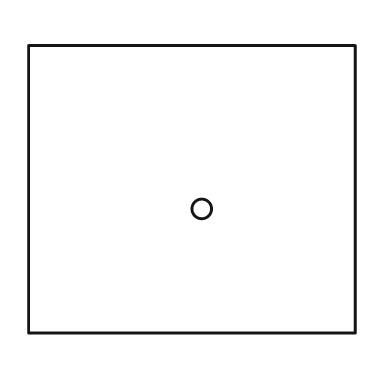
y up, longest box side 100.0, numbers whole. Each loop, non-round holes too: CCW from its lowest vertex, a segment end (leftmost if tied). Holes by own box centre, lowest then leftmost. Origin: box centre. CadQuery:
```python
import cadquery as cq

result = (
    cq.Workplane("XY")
    .moveTo(-50.0, -44.0)
    .lineTo(50.0, -44.0)
    .lineTo(50.0, 44.0)
    .lineTo(-50.0, 44.0)
    .close()
    .moveTo(3.0, -6.0)
    .circle(3.0)
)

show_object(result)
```